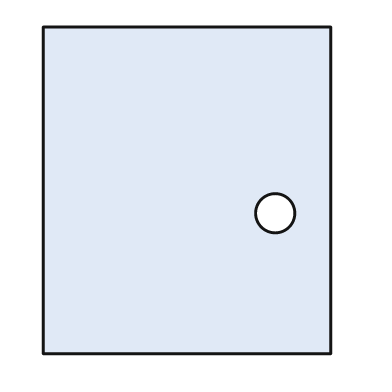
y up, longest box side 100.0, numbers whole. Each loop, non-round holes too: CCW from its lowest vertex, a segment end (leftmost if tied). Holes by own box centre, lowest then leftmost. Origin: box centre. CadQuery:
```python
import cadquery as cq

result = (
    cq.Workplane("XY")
    .moveTo(-44.0, -50.0)
    .lineTo(44.0, -50.0)
    .lineTo(44.0, 50.0)
    .lineTo(-44.0, 50.0)
    .close()
    .moveTo(27.0, -7.0)
    .circle(6.0)
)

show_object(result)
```